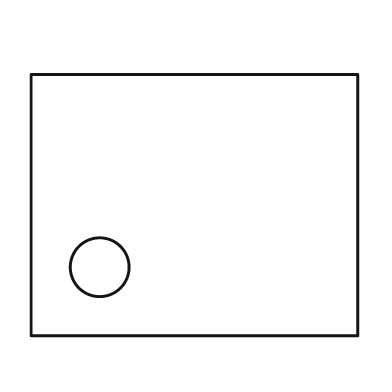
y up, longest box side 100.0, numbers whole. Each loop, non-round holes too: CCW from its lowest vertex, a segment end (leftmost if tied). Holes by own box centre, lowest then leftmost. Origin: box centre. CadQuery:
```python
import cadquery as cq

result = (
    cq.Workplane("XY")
    .moveTo(-50.0, -40.0)
    .lineTo(50.0, -40.0)
    .lineTo(50.0, 40.0)
    .lineTo(-50.0, 40.0)
    .close()
    .moveTo(-29.0, -19.0)
    .circle(9.0)
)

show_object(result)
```